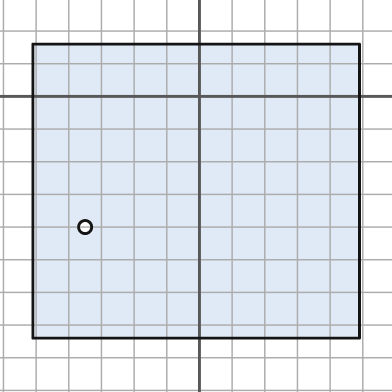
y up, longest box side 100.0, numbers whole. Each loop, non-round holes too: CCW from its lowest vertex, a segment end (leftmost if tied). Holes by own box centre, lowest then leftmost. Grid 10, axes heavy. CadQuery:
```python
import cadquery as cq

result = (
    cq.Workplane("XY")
    .moveTo(-51.0, -74.0)
    .lineTo(49.0, -74.0)
    .lineTo(49.0, 16.0)
    .lineTo(-51.0, 16.0)
    .close()
    .moveTo(-35.0, -40.0)
    .circle(2.0)
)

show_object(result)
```